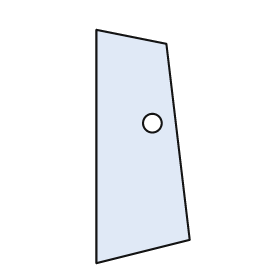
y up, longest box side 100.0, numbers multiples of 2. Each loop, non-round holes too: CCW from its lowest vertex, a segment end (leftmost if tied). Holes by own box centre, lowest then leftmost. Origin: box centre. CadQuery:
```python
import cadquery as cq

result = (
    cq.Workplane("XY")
    .moveTo(-20.0, -50.0)
    .lineTo(20.0, -40.0)
    .lineTo(10.0, 44.0)
    .lineTo(-20.0, 50.0)
    .close()
    .moveTo(4.0, 10.0)
    .circle(4.0)
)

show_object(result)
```